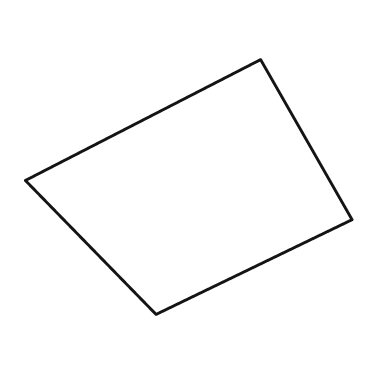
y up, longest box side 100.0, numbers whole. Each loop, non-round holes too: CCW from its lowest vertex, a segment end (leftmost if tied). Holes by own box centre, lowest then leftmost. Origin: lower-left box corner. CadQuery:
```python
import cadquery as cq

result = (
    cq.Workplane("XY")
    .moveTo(40.0, 0.0)
    .lineTo(100.0, 29.0)
    .lineTo(72.0, 78.0)
    .lineTo(0.0, 41.0)
    .close()
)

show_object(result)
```